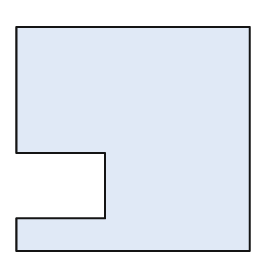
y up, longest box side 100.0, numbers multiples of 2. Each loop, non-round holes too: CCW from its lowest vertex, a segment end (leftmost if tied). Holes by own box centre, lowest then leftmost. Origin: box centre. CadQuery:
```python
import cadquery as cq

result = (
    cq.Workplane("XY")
    .moveTo(-50.0, -48.0)
    .lineTo(50.0, -48.0)
    .lineTo(50.0, 48.0)
    .lineTo(-50.0, 48.0)
    .lineTo(-50.0, -6.0)
    .lineTo(-12.0, -6.0)
    .lineTo(-12.0, -34.0)
    .lineTo(-50.0, -34.0)
    .close()
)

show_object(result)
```